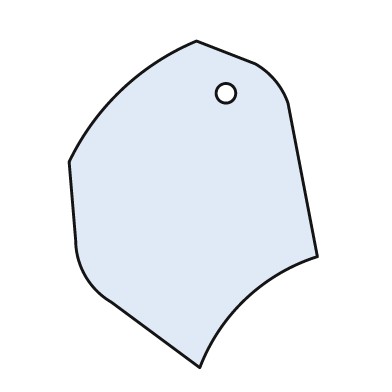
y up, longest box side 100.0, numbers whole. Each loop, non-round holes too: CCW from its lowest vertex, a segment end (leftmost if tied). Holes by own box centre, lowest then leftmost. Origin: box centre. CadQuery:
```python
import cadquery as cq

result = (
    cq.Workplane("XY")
    .moveTo(2.0, -50.0)
    .threePointArc((16.0, -29.0), (38.0, -16.0))
    .lineTo(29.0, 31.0)
    .threePointArc((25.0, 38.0), (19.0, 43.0))
    .lineTo(1.0, 50.0)
    .threePointArc((-22.0, 35.0), (-38.0, 13.0))
    .lineTo(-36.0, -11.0)
    .threePointArc((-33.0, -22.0), (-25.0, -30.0))
    .close()
    .moveTo(10.0, 34.0)
    .circle(3.0)
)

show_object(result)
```